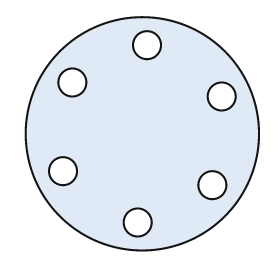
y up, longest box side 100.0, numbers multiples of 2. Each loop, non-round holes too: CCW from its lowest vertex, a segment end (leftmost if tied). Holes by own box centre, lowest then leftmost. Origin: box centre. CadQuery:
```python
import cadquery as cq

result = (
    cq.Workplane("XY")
    .moveTo(0.0, 0.0)
    .circle(50.0)
    .moveTo(-2.0, -38.0)
    .circle(6.0)
    .moveTo(30.0, -22.0)
    .circle(6.0)
    .moveTo(-34.0, -16.0)
    .circle(6.0)
    .moveTo(34.0, 16.0)
    .circle(6.0)
    .moveTo(-30.0, 22.0)
    .circle(6.0)
    .moveTo(2.0, 38.0)
    .circle(6.0)
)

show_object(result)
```